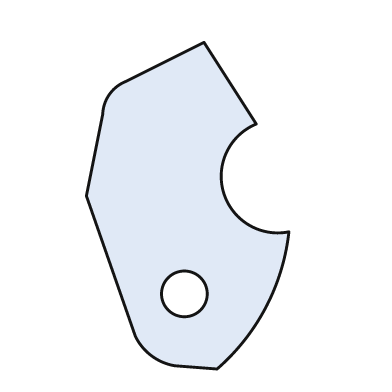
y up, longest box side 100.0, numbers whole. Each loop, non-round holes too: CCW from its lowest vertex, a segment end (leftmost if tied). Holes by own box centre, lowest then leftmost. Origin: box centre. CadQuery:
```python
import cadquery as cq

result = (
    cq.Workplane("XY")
    .moveTo(9.0, -50.0)
    .threePointArc((24.0, -31.0), (31.0, -8.0))
    .threePointArc((11.0, 4.0), (21.0, 25.0))
    .lineTo(5.0, 50.0)
    .lineTo(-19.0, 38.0)
    .threePointArc((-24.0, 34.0), (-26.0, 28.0))
    .lineTo(-31.0, 3.0)
    .lineTo(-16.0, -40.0)
    .threePointArc((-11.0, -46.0), (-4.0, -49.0))
    .close()
    .moveTo(-1.0, -27.0)
    .circle(7.0)
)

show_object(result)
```